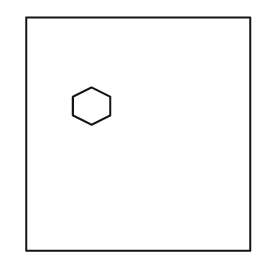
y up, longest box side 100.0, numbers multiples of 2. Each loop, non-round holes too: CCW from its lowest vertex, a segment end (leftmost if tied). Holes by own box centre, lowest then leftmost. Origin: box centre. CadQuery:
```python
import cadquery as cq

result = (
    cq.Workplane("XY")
    .moveTo(-48.0, -50.0)
    .lineTo(48.0, -50.0)
    .lineTo(48.0, 50.0)
    .lineTo(-48.0, 50.0)
    .close()
    .moveTo(-20.0, 4.0)
    .lineTo(-12.0, 8.0)
    .lineTo(-12.0, 16.0)
    .lineTo(-20.0, 20.0)
    .lineTo(-28.0, 16.0)
    .lineTo(-28.0, 8.0)
    .close()
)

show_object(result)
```